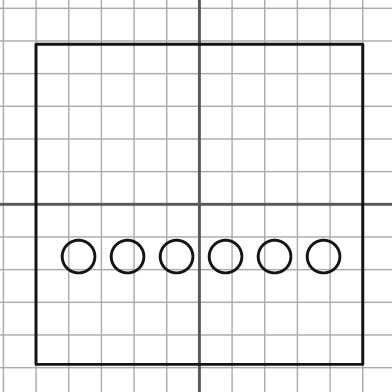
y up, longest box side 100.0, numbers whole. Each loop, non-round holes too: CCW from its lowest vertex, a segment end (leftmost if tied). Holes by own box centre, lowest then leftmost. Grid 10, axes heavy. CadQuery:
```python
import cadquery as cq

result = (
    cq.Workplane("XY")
    .moveTo(-50.0, -49.0)
    .lineTo(50.0, -49.0)
    .lineTo(50.0, 49.0)
    .lineTo(-50.0, 49.0)
    .close()
    .moveTo(-37.0, -16.0)
    .circle(5.0)
    .moveTo(-22.0, -16.0)
    .circle(5.0)
    .moveTo(-7.0, -16.0)
    .circle(5.0)
    .moveTo(8.0, -16.0)
    .circle(5.0)
    .moveTo(23.0, -16.0)
    .circle(5.0)
    .moveTo(38.0, -16.0)
    .circle(5.0)
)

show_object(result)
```